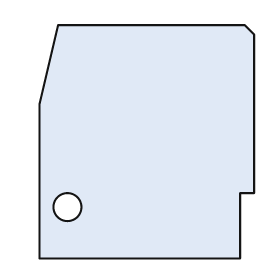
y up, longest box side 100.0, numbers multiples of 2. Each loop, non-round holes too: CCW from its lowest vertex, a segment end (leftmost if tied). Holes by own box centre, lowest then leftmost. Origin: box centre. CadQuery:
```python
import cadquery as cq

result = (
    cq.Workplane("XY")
    .moveTo(-46.0, -50.0)
    .lineTo(40.0, -50.0)
    .lineTo(40.0, -22.0)
    .lineTo(46.0, -22.0)
    .lineTo(46.0, 46.0)
    .lineTo(42.0, 50.0)
    .lineTo(-38.0, 50.0)
    .lineTo(-46.0, 16.0)
    .close()
    .moveTo(-34.0, -28.0)
    .circle(6.0)
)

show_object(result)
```